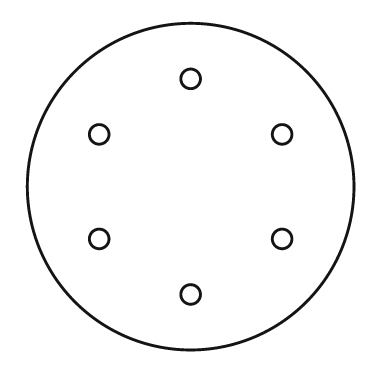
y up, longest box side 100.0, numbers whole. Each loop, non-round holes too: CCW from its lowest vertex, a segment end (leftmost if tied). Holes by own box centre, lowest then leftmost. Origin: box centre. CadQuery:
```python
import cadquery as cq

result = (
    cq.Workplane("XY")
    .moveTo(0.0, 0.0)
    .circle(50.0)
    .moveTo(0.0, -33.0)
    .circle(3.0)
    .moveTo(-28.0, -16.0)
    .circle(3.0)
    .moveTo(28.0, -16.0)
    .circle(3.0)
    .moveTo(-28.0, 16.0)
    .circle(3.0)
    .moveTo(28.0, 16.0)
    .circle(3.0)
    .moveTo(0.0, 33.0)
    .circle(3.0)
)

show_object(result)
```